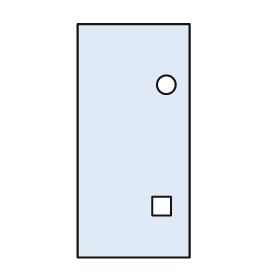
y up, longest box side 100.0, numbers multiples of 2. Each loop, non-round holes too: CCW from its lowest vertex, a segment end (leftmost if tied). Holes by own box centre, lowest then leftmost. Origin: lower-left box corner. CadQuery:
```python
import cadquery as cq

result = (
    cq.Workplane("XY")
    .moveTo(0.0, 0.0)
    .lineTo(48.0, 0.0)
    .lineTo(48.0, 100.0)
    .lineTo(0.0, 100.0)
    .close()
    .moveTo(32.0, 18.0)
    .lineTo(40.0, 18.0)
    .lineTo(40.0, 26.0)
    .lineTo(32.0, 26.0)
    .close()
    .moveTo(38.0, 74.0)
    .circle(4.0)
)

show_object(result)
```